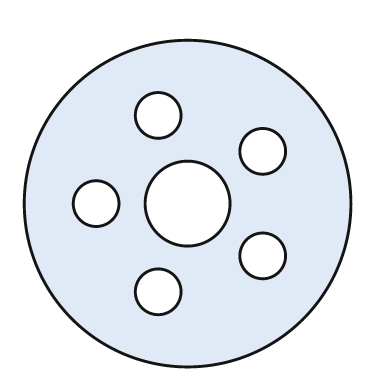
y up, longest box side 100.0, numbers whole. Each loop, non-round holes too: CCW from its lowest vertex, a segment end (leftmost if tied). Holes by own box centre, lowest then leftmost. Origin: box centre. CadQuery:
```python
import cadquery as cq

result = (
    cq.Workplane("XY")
    .moveTo(0.0, 0.0)
    .circle(50.0)
    .moveTo(-9.0, -27.0)
    .circle(7.0)
    .moveTo(23.0, -16.0)
    .circle(7.0)
    .moveTo(-28.0, 0.0)
    .circle(7.0)
    .moveTo(0.0, 0.0)
    .circle(13.0)
    .moveTo(23.0, 16.0)
    .circle(7.0)
    .moveTo(-9.0, 27.0)
    .circle(7.0)
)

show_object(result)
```